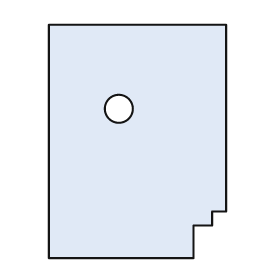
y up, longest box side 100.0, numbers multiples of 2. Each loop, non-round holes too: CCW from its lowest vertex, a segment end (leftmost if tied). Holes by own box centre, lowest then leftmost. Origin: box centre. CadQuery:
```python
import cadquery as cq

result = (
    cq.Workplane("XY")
    .moveTo(-38.0, -50.0)
    .lineTo(24.0, -50.0)
    .lineTo(24.0, -36.0)
    .lineTo(32.0, -36.0)
    .lineTo(32.0, -30.0)
    .lineTo(38.0, -30.0)
    .lineTo(38.0, 50.0)
    .lineTo(-38.0, 50.0)
    .close()
    .moveTo(-8.0, 14.0)
    .circle(6.0)
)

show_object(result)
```